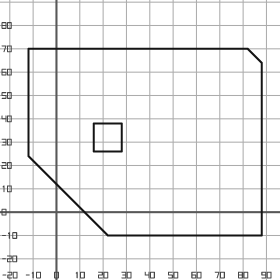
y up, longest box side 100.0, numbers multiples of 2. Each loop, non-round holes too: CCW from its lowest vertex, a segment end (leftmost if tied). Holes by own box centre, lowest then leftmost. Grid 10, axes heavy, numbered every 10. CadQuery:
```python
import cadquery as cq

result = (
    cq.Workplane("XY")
    .moveTo(22.0, -10.0)
    .lineTo(88.0, -10.0)
    .lineTo(88.0, 64.0)
    .lineTo(82.0, 70.0)
    .lineTo(-12.0, 70.0)
    .lineTo(-12.0, 24.0)
    .close()
    .moveTo(16.0, 26.0)
    .lineTo(28.0, 26.0)
    .lineTo(28.0, 38.0)
    .lineTo(16.0, 38.0)
    .close()
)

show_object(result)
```